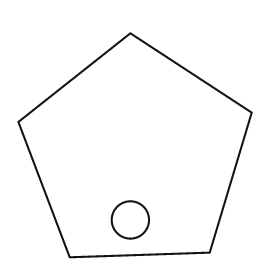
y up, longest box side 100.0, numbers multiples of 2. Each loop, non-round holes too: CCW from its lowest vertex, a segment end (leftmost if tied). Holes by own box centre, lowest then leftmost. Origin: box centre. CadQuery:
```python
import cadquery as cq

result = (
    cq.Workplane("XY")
    .moveTo(-28.0, -48.0)
    .lineTo(32.0, -46.0)
    .lineTo(50.0, 14.0)
    .lineTo(-2.0, 48.0)
    .lineTo(-50.0, 10.0)
    .close()
    .moveTo(-2.0, -32.0)
    .circle(8.0)
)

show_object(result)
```